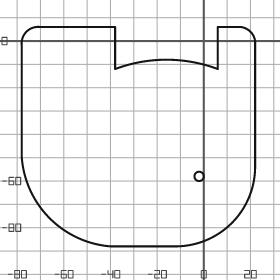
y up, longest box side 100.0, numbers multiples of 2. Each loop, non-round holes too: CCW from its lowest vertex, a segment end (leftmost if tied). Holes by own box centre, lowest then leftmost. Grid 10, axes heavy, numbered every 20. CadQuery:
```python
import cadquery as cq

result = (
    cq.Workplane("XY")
    .moveTo(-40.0, -88.0)
    .lineTo(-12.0, -88.0)
    .threePointArc((12.0, -78.0), (22.0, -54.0))
    .lineTo(22.0, 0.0)
    .threePointArc((20.0, 4.0), (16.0, 6.0))
    .lineTo(6.0, 6.0)
    .lineTo(6.0, -12.0)
    .threePointArc((-16.0, -8.0), (-38.0, -12.0))
    .lineTo(-38.0, 6.0)
    .lineTo(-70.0, 6.0)
    .threePointArc((-76.0, 4.0), (-78.0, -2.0))
    .lineTo(-78.0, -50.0)
    .threePointArc((-66.0, -76.0), (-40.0, -88.0))
    .close()
    .moveTo(-2.0, -58.0)
    .circle(2.0)
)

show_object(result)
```